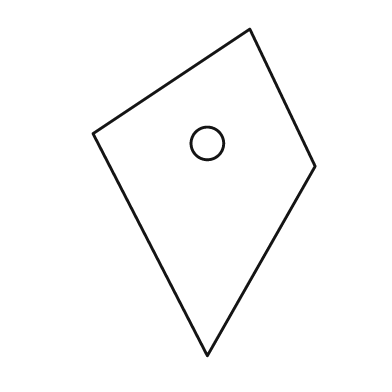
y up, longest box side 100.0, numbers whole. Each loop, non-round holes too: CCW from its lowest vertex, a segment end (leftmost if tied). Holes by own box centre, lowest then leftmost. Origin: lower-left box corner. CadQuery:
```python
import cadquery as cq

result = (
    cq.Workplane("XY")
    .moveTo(35.0, 0.0)
    .lineTo(68.0, 58.0)
    .lineTo(48.0, 100.0)
    .lineTo(0.0, 68.0)
    .close()
    .moveTo(35.0, 65.0)
    .circle(5.0)
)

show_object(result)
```